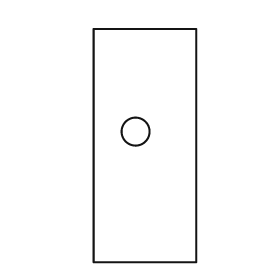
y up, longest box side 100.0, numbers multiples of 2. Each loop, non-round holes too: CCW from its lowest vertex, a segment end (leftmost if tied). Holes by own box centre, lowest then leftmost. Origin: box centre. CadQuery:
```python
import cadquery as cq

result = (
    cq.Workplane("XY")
    .moveTo(-22.0, -50.0)
    .lineTo(22.0, -50.0)
    .lineTo(22.0, 50.0)
    .lineTo(-22.0, 50.0)
    .close()
    .moveTo(-4.0, 6.0)
    .circle(6.0)
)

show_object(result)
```